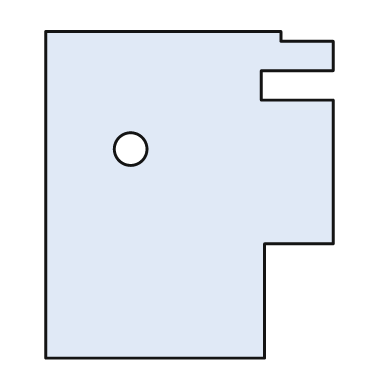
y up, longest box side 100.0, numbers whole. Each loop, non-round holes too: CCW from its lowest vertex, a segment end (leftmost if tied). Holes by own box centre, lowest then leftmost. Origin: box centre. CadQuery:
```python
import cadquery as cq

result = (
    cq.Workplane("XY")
    .moveTo(-44.0, -50.0)
    .lineTo(23.0, -50.0)
    .lineTo(23.0, -15.0)
    .lineTo(44.0, -15.0)
    .lineTo(44.0, 29.0)
    .lineTo(22.0, 29.0)
    .lineTo(22.0, 38.0)
    .lineTo(44.0, 38.0)
    .lineTo(44.0, 47.0)
    .lineTo(28.0, 47.0)
    .lineTo(28.0, 50.0)
    .lineTo(-44.0, 50.0)
    .close()
    .moveTo(-18.0, 14.0)
    .circle(5.0)
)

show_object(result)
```